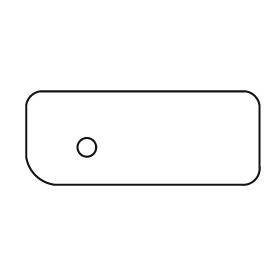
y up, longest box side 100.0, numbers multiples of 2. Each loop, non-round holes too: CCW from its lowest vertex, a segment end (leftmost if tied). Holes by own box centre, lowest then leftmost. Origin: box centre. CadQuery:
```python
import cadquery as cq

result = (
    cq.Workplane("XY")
    .moveTo(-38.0, -20.0)
    .lineTo(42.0, -20.0)
    .threePointArc((48.0, -18.0), (50.0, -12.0))
    .lineTo(50.0, 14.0)
    .threePointArc((48.0, 18.0), (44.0, 20.0))
    .lineTo(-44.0, 20.0)
    .threePointArc((-48.0, 18.0), (-50.0, 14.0))
    .lineTo(-50.0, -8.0)
    .threePointArc((-46.0, -16.0), (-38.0, -20.0))
    .close()
    .moveTo(-24.0, -4.0)
    .circle(4.0)
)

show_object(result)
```